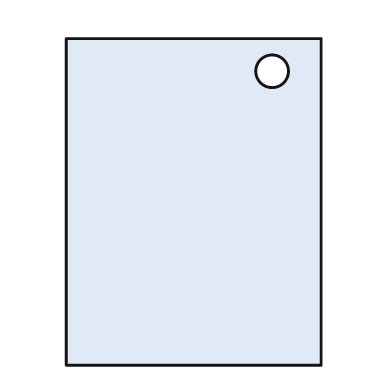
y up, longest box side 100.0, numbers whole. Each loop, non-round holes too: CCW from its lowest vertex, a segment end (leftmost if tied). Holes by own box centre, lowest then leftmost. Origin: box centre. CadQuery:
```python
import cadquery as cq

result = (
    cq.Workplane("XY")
    .moveTo(-39.0, -50.0)
    .lineTo(39.0, -50.0)
    .lineTo(39.0, 50.0)
    .lineTo(-39.0, 50.0)
    .close()
    .moveTo(24.0, 40.0)
    .circle(5.0)
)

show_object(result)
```